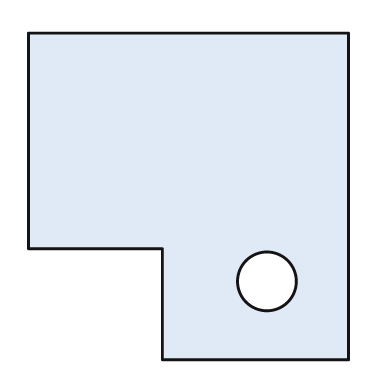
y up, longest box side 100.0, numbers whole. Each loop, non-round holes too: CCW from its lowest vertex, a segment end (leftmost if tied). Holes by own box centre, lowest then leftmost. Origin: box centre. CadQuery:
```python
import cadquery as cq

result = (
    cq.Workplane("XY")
    .moveTo(-8.0, -50.0)
    .lineTo(49.0, -50.0)
    .lineTo(49.0, 50.0)
    .lineTo(-49.0, 50.0)
    .lineTo(-49.0, -16.0)
    .lineTo(-8.0, -16.0)
    .close()
    .moveTo(24.0, -26.0)
    .circle(9.0)
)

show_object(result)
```